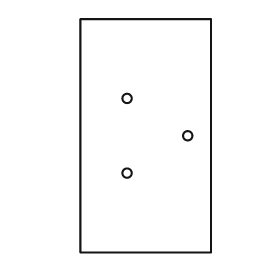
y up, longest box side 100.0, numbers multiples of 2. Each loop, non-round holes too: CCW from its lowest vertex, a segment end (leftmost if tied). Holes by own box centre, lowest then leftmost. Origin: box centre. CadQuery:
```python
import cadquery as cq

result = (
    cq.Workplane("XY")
    .moveTo(-28.0, -50.0)
    .lineTo(28.0, -50.0)
    .lineTo(28.0, 50.0)
    .lineTo(-28.0, 50.0)
    .close()
    .moveTo(-8.0, -16.0)
    .circle(2.0)
    .moveTo(18.0, 0.0)
    .circle(2.0)
    .moveTo(-8.0, 16.0)
    .circle(2.0)
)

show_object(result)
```